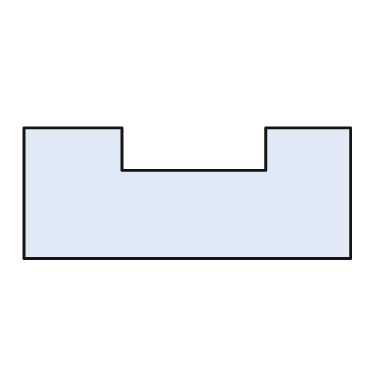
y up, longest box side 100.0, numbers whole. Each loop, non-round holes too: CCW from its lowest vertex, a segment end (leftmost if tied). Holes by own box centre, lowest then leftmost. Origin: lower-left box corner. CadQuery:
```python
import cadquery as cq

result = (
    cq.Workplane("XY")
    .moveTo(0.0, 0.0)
    .lineTo(100.0, 0.0)
    .lineTo(100.0, 40.0)
    .lineTo(74.0, 40.0)
    .lineTo(74.0, 27.0)
    .lineTo(30.0, 27.0)
    .lineTo(30.0, 40.0)
    .lineTo(0.0, 40.0)
    .close()
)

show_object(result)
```